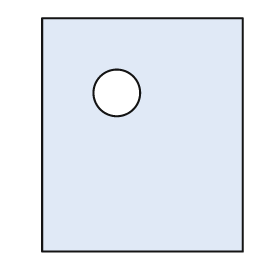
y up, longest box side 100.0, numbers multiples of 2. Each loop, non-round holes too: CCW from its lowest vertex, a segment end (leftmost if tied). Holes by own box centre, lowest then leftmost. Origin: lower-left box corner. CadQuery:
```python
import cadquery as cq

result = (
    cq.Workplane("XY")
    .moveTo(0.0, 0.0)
    .lineTo(86.0, 0.0)
    .lineTo(86.0, 100.0)
    .lineTo(0.0, 100.0)
    .close()
    .moveTo(32.0, 68.0)
    .circle(10.0)
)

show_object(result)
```